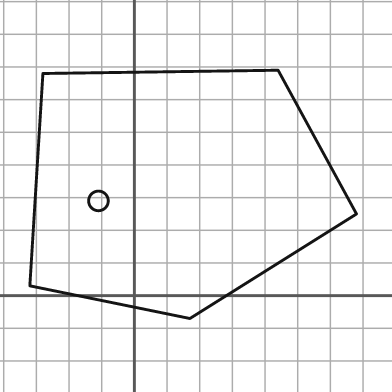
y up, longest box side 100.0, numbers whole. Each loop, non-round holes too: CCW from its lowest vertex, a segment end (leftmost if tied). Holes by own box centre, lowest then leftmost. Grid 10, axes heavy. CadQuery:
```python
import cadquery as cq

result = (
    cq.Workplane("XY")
    .moveTo(17.0, -7.0)
    .lineTo(68.0, 25.0)
    .lineTo(44.0, 69.0)
    .lineTo(-28.0, 68.0)
    .lineTo(-32.0, 3.0)
    .close()
    .moveTo(-11.0, 29.0)
    .circle(3.0)
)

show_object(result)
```